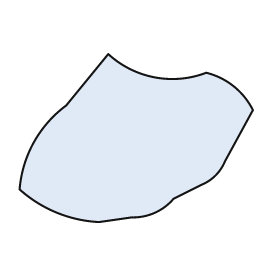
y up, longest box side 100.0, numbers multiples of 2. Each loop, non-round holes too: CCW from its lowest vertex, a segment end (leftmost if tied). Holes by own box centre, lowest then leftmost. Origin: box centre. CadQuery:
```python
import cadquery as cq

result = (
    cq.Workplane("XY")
    .moveTo(-16.0, -36.0)
    .lineTo(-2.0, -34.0)
    .threePointArc((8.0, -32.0), (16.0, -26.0))
    .lineTo(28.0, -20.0)
    .threePointArc((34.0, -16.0), (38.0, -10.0))
    .lineTo(50.0, 12.0)
    .threePointArc((42.0, 22.0), (30.0, 28.0))
    .threePointArc((8.0, 26.0), (-12.0, 36.0))
    .lineTo(-30.0, 14.0)
    .threePointArc((-44.0, -2.0), (-50.0, -22.0))
    .threePointArc((-34.0, -32.0), (-16.0, -36.0))
    .close()
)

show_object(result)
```